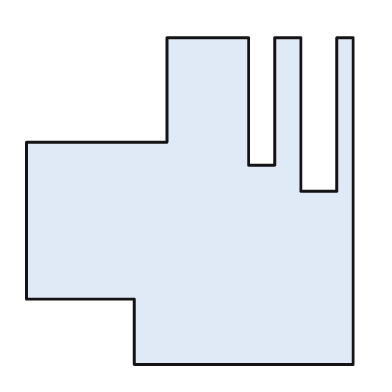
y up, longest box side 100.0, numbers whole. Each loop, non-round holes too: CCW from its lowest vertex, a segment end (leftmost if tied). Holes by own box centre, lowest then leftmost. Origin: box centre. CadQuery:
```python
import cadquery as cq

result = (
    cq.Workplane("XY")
    .moveTo(-17.0, -50.0)
    .lineTo(50.0, -50.0)
    .lineTo(50.0, 50.0)
    .lineTo(45.0, 50.0)
    .lineTo(45.0, 3.0)
    .lineTo(34.0, 3.0)
    .lineTo(34.0, 50.0)
    .lineTo(26.0, 50.0)
    .lineTo(26.0, 11.0)
    .lineTo(18.0, 11.0)
    .lineTo(18.0, 50.0)
    .lineTo(-7.0, 50.0)
    .lineTo(-7.0, 18.0)
    .lineTo(-50.0, 18.0)
    .lineTo(-50.0, -30.0)
    .lineTo(-17.0, -30.0)
    .close()
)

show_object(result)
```